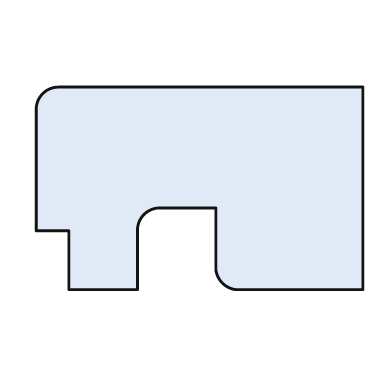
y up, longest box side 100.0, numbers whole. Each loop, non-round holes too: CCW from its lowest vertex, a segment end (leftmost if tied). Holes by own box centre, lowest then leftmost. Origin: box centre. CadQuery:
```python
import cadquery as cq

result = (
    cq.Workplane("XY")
    .moveTo(-40.0, -31.0)
    .lineTo(-19.0, -31.0)
    .lineTo(-19.0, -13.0)
    .threePointArc((-17.0, -8.0), (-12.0, -6.0))
    .lineTo(5.0, -6.0)
    .lineTo(5.0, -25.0)
    .threePointArc((7.0, -29.0), (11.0, -31.0))
    .lineTo(50.0, -31.0)
    .lineTo(50.0, 31.0)
    .lineTo(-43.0, 31.0)
    .threePointArc((-48.0, 29.0), (-50.0, 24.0))
    .lineTo(-50.0, -13.0)
    .lineTo(-40.0, -13.0)
    .close()
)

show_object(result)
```